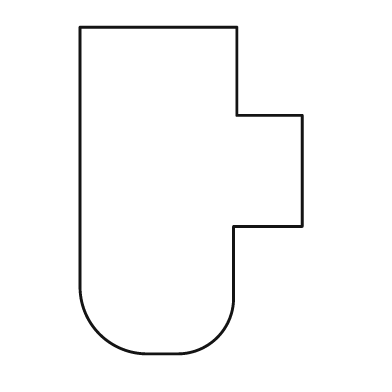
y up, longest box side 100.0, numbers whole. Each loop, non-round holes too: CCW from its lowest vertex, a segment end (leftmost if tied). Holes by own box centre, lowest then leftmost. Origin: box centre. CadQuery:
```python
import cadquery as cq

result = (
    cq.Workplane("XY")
    .moveTo(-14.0, -50.0)
    .lineTo(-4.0, -50.0)
    .threePointArc((8.0, -45.0), (13.0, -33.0))
    .lineTo(13.0, -11.0)
    .lineTo(34.0, -11.0)
    .lineTo(34.0, 23.0)
    .lineTo(14.0, 23.0)
    .lineTo(14.0, 50.0)
    .lineTo(-34.0, 50.0)
    .lineTo(-34.0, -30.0)
    .threePointArc((-28.0, -44.0), (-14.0, -50.0))
    .close()
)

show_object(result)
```